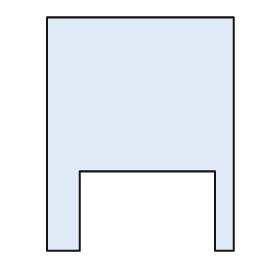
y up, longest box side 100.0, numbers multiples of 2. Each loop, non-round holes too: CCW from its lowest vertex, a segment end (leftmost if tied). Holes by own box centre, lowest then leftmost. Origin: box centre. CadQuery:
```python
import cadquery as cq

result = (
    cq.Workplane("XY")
    .moveTo(-40.0, -50.0)
    .lineTo(-26.0, -50.0)
    .lineTo(-26.0, -16.0)
    .lineTo(32.0, -16.0)
    .lineTo(32.0, -50.0)
    .lineTo(40.0, -50.0)
    .lineTo(40.0, 50.0)
    .lineTo(-40.0, 50.0)
    .close()
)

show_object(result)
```